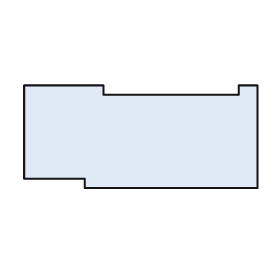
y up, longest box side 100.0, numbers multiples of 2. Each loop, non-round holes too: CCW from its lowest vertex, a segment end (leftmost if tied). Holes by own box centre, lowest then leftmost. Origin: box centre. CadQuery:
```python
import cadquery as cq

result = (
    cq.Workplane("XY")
    .moveTo(-24.0, -22.0)
    .lineTo(50.0, -22.0)
    .lineTo(50.0, 22.0)
    .lineTo(42.0, 22.0)
    .lineTo(42.0, 18.0)
    .lineTo(-16.0, 18.0)
    .lineTo(-16.0, 22.0)
    .lineTo(-50.0, 22.0)
    .lineTo(-50.0, -18.0)
    .lineTo(-24.0, -18.0)
    .close()
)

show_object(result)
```